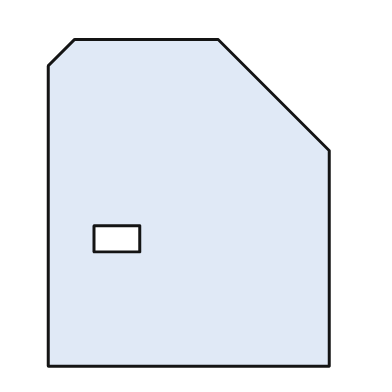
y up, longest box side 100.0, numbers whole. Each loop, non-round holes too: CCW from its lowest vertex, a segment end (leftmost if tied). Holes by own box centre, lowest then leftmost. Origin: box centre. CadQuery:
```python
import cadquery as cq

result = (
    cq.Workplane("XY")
    .moveTo(-43.0, -50.0)
    .lineTo(43.0, -50.0)
    .lineTo(43.0, 16.0)
    .lineTo(9.0, 50.0)
    .lineTo(-35.0, 50.0)
    .lineTo(-43.0, 42.0)
    .close()
    .moveTo(-29.0, -15.0)
    .lineTo(-15.0, -15.0)
    .lineTo(-15.0, -7.0)
    .lineTo(-29.0, -7.0)
    .close()
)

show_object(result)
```